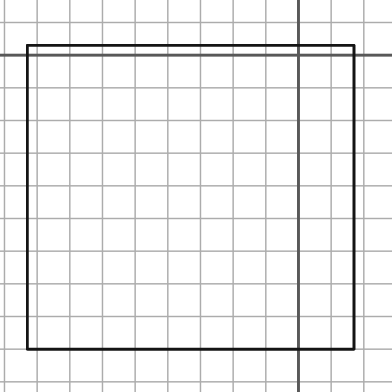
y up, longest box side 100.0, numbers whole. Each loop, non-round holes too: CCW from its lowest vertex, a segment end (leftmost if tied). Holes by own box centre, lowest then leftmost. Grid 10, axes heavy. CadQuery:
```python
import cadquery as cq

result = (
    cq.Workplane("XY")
    .moveTo(-83.0, -90.0)
    .lineTo(17.0, -90.0)
    .lineTo(17.0, 3.0)
    .lineTo(-83.0, 3.0)
    .close()
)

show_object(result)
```